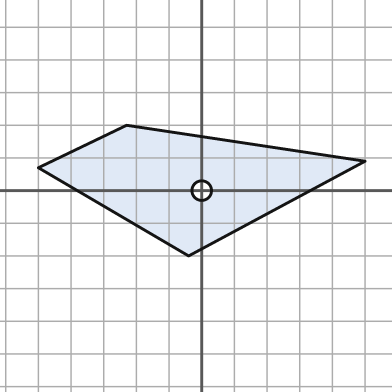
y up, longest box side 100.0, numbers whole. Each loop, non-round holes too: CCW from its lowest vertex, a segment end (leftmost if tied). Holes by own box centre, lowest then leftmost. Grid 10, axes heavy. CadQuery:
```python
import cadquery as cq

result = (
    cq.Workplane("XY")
    .moveTo(-4.0, -20.0)
    .lineTo(50.0, 9.0)
    .lineTo(-23.0, 20.0)
    .lineTo(-50.0, 7.0)
    .close()
    .moveTo(0.0, 0.0)
    .circle(3.0)
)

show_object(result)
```